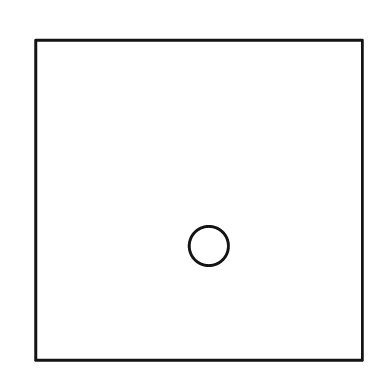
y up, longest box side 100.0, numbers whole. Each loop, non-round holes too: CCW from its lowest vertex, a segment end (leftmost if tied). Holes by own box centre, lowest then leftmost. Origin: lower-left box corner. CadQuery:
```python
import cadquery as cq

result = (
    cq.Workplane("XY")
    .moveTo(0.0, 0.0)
    .lineTo(100.0, 0.0)
    .lineTo(100.0, 98.0)
    .lineTo(0.0, 98.0)
    .close()
    .moveTo(53.0, 35.0)
    .circle(6.0)
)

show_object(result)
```